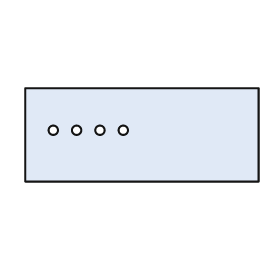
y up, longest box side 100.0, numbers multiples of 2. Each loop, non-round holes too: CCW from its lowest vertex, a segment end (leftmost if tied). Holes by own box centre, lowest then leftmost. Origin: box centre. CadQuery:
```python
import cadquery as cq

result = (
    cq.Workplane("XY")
    .moveTo(-50.0, -20.0)
    .lineTo(50.0, -20.0)
    .lineTo(50.0, 20.0)
    .lineTo(-50.0, 20.0)
    .close()
    .moveTo(-38.0, 2.0)
    .circle(2.0)
    .moveTo(-28.0, 2.0)
    .circle(2.0)
    .moveTo(-18.0, 2.0)
    .circle(2.0)
    .moveTo(-8.0, 2.0)
    .circle(2.0)
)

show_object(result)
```